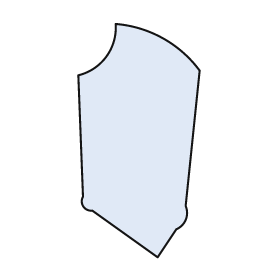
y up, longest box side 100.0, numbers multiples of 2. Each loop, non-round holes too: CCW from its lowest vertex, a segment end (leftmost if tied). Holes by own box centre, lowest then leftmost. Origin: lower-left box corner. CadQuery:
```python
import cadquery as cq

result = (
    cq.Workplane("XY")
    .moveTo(34.0, 0.0)
    .lineTo(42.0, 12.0)
    .threePointArc((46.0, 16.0), (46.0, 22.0))
    .lineTo(52.0, 80.0)
    .threePointArc((36.0, 94.0), (16.0, 100.0))
    .threePointArc((12.0, 86.0), (0.0, 78.0))
    .lineTo(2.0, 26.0)
    .threePointArc((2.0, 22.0), (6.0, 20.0))
    .close()
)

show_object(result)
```